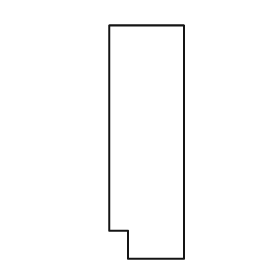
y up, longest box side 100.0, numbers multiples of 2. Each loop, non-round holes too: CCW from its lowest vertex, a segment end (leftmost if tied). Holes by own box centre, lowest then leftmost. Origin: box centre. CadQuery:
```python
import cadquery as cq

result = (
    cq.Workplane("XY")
    .moveTo(-8.0, -50.0)
    .lineTo(16.0, -50.0)
    .lineTo(16.0, 50.0)
    .lineTo(-16.0, 50.0)
    .lineTo(-16.0, -38.0)
    .lineTo(-8.0, -38.0)
    .close()
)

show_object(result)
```